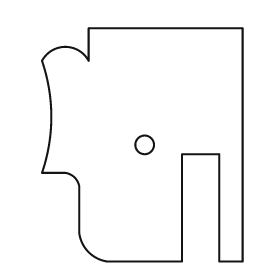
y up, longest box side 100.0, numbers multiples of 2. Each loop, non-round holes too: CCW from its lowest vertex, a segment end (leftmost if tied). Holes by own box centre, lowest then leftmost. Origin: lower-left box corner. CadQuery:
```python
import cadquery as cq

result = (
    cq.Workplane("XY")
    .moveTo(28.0, 0.0)
    .lineTo(60.0, 0.0)
    .lineTo(60.0, 46.0)
    .lineTo(76.0, 46.0)
    .lineTo(76.0, 0.0)
    .lineTo(86.0, 0.0)
    .lineTo(86.0, 100.0)
    .lineTo(20.0, 100.0)
    .lineTo(20.0, 86.0)
    .threePointArc((10.0, 92.0), (0.0, 86.0))
    .threePointArc((4.0, 62.0), (0.0, 38.0))
    .lineTo(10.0, 38.0)
    .threePointArc((14.0, 36.0), (16.0, 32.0))
    .lineTo(16.0, 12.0)
    .threePointArc((20.0, 4.0), (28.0, 0.0))
    .close()
    .moveTo(44.0, 50.0)
    .circle(4.0)
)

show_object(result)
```